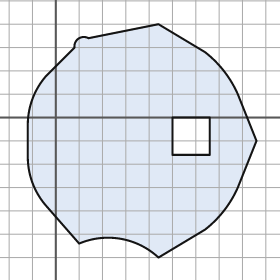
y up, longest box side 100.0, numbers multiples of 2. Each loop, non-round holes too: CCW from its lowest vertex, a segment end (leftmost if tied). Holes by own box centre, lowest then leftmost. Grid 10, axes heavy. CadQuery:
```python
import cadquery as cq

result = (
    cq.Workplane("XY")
    .moveTo(44.0, -60.0)
    .lineTo(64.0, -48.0)
    .threePointArc((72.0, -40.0), (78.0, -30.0))
    .lineTo(86.0, -10.0)
    .lineTo(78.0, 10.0)
    .threePointArc((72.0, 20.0), (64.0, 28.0))
    .lineTo(44.0, 40.0)
    .lineTo(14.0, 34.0)
    .threePointArc((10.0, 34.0), (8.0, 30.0))
    .lineTo(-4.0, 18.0)
    .threePointArc((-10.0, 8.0), (-12.0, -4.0))
    .lineTo(-12.0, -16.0)
    .threePointArc((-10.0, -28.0), (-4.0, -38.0))
    .lineTo(10.0, -54.0)
    .threePointArc((28.0, -52.0), (44.0, -60.0))
    .close()
    .moveTo(50.0, -16.0)
    .lineTo(66.0, -16.0)
    .lineTo(66.0, 0.0)
    .lineTo(50.0, 0.0)
    .close()
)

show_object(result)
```